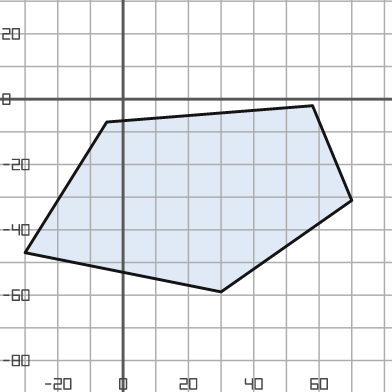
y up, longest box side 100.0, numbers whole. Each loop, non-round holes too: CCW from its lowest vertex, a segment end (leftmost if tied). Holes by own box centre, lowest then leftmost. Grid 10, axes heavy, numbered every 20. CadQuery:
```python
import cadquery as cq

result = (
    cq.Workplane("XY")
    .moveTo(30.0, -59.0)
    .lineTo(70.0, -31.0)
    .lineTo(58.0, -2.0)
    .lineTo(-5.0, -7.0)
    .lineTo(-30.0, -47.0)
    .close()
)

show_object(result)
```